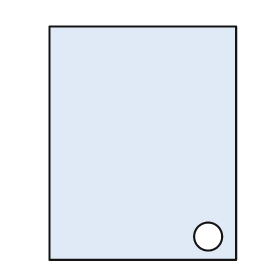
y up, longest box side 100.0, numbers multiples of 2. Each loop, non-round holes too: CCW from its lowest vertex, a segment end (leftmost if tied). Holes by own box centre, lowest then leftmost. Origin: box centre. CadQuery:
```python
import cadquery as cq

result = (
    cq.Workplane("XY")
    .moveTo(-40.0, -50.0)
    .lineTo(40.0, -50.0)
    .lineTo(40.0, 50.0)
    .lineTo(-40.0, 50.0)
    .close()
    .moveTo(28.0, -40.0)
    .circle(6.0)
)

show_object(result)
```